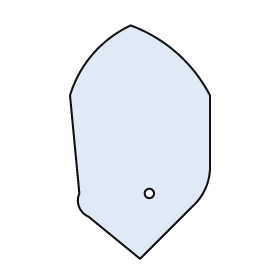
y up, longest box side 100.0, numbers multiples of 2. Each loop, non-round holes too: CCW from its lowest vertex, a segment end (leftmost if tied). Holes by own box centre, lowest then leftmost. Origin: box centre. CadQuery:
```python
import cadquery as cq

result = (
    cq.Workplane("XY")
    .moveTo(0.0, -50.0)
    .lineTo(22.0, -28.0)
    .threePointArc((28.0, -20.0), (30.0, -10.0))
    .lineTo(30.0, 20.0)
    .threePointArc((16.0, 38.0), (-4.0, 50.0))
    .threePointArc((-20.0, 38.0), (-30.0, 20.0))
    .lineTo(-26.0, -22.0)
    .threePointArc((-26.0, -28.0), (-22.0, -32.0))
    .close()
    .moveTo(4.0, -22.0)
    .circle(2.0)
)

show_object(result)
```